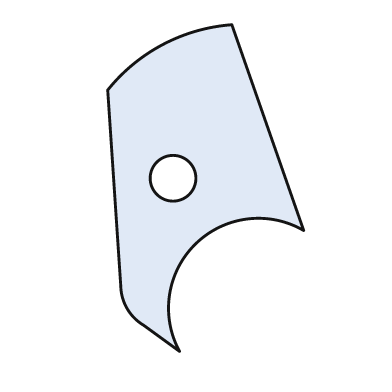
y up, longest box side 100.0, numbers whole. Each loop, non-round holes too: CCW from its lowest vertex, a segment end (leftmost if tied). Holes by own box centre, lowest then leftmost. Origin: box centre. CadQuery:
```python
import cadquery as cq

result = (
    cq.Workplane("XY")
    .moveTo(-8.0, -50.0)
    .threePointArc((-3.0, -17.0), (30.0, -13.0))
    .lineTo(8.0, 50.0)
    .threePointArc((-13.0, 44.0), (-30.0, 30.0))
    .lineTo(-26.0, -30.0)
    .threePointArc((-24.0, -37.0), (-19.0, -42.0))
    .close()
    .moveTo(-10.0, 3.0)
    .circle(7.0)
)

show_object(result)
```